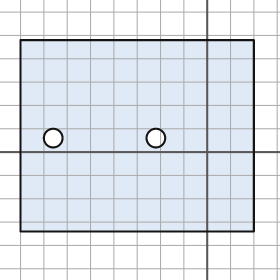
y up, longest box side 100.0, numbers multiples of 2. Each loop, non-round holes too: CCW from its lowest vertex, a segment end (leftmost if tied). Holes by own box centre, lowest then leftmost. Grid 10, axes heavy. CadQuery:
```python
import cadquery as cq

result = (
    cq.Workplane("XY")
    .moveTo(-80.0, -34.0)
    .lineTo(20.0, -34.0)
    .lineTo(20.0, 48.0)
    .lineTo(-80.0, 48.0)
    .close()
    .moveTo(-66.0, 6.0)
    .circle(4.0)
    .moveTo(-22.0, 6.0)
    .circle(4.0)
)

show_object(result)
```